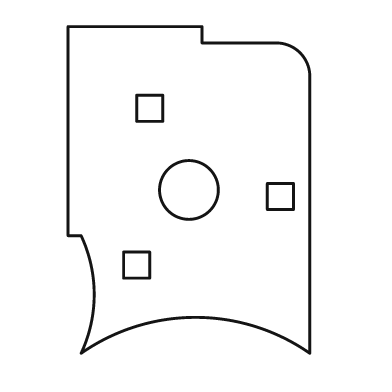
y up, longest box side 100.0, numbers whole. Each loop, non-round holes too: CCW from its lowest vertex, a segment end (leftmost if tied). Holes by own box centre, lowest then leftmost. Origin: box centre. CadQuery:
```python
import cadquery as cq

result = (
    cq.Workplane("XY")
    .moveTo(-33.0, -50.0)
    .threePointArc((2.0, -39.0), (37.0, -50.0))
    .lineTo(37.0, 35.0)
    .threePointArc((34.0, 42.0), (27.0, 45.0))
    .lineTo(4.0, 45.0)
    .lineTo(4.0, 50.0)
    .lineTo(-37.0, 50.0)
    .lineTo(-37.0, -14.0)
    .lineTo(-33.0, -14.0)
    .threePointArc((-29.0, -32.0), (-33.0, -50.0))
    .close()
    .moveTo(-20.0, -27.0)
    .lineTo(-12.0, -27.0)
    .lineTo(-12.0, -19.0)
    .lineTo(-20.0, -19.0)
    .close()
    .moveTo(24.0, -6.0)
    .lineTo(32.0, -6.0)
    .lineTo(32.0, 2.0)
    .lineTo(24.0, 2.0)
    .close()
    .moveTo(0.0, 0.0)
    .circle(9.0)
    .moveTo(-16.0, 21.0)
    .lineTo(-8.0, 21.0)
    .lineTo(-8.0, 29.0)
    .lineTo(-16.0, 29.0)
    .close()
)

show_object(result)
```